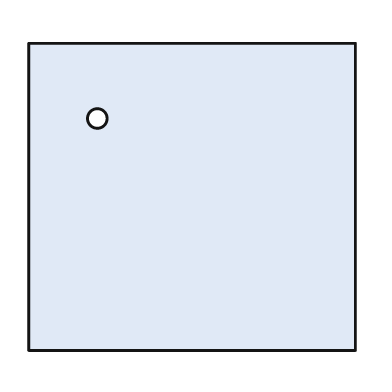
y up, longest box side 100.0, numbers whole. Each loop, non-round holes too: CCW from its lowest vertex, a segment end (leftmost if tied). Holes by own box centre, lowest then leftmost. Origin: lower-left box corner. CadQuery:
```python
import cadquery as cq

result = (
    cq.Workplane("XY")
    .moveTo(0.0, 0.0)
    .lineTo(100.0, 0.0)
    .lineTo(100.0, 94.0)
    .lineTo(0.0, 94.0)
    .close()
    .moveTo(21.0, 71.0)
    .circle(3.0)
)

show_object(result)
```